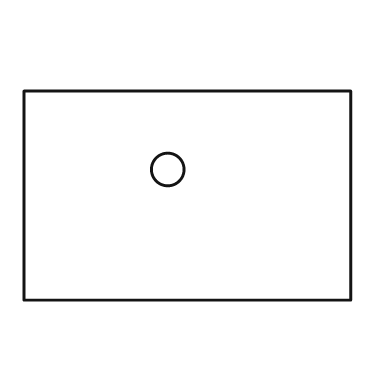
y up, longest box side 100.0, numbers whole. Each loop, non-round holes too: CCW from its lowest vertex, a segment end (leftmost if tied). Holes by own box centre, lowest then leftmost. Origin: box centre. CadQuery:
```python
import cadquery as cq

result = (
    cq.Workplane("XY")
    .moveTo(-50.0, -32.0)
    .lineTo(50.0, -32.0)
    .lineTo(50.0, 32.0)
    .lineTo(-50.0, 32.0)
    .close()
    .moveTo(-6.0, 8.0)
    .circle(5.0)
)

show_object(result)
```